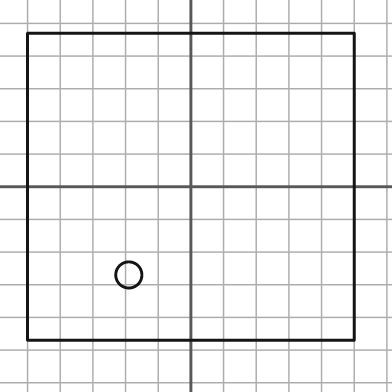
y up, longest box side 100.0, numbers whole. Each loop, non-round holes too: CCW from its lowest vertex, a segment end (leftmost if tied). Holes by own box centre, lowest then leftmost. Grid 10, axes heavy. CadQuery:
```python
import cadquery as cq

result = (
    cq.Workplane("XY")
    .moveTo(-50.0, -47.0)
    .lineTo(50.0, -47.0)
    .lineTo(50.0, 47.0)
    .lineTo(-50.0, 47.0)
    .close()
    .moveTo(-19.0, -27.0)
    .circle(4.0)
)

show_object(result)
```